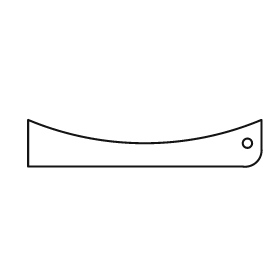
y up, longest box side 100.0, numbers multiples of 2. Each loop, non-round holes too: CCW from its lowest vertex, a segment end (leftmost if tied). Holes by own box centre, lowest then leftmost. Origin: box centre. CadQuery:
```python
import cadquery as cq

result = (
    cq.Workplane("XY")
    .moveTo(-50.0, -10.0)
    .lineTo(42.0, -10.0)
    .threePointArc((48.0, -8.0), (50.0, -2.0))
    .lineTo(50.0, 10.0)
    .threePointArc((0.0, 0.0), (-50.0, 10.0))
    .close()
    .moveTo(44.0, 0.0)
    .circle(2.0)
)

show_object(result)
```